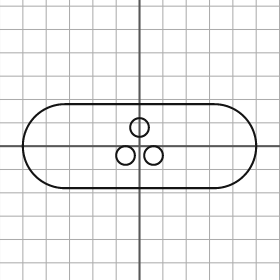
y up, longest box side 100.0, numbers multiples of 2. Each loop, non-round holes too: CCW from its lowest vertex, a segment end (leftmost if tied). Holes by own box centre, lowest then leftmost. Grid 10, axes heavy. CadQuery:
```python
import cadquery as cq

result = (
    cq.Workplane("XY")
    .moveTo(-32.0, -18.0)
    .lineTo(32.0, -18.0)
    .threePointArc((50.0, 0.0), (32.0, 18.0))
    .lineTo(-32.0, 18.0)
    .threePointArc((-50.0, 0.0), (-32.0, -18.0))
    .close()
    .moveTo(-6.0, -4.0)
    .circle(4.0)
    .moveTo(6.0, -4.0)
    .circle(4.0)
    .moveTo(0.0, 8.0)
    .circle(4.0)
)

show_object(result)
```